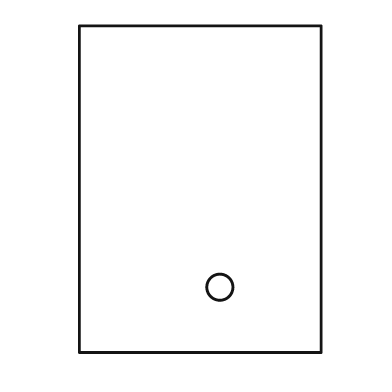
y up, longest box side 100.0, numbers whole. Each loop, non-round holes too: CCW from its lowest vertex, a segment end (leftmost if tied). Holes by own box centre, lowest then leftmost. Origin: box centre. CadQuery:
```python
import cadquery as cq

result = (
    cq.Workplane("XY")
    .moveTo(-37.0, -50.0)
    .lineTo(37.0, -50.0)
    .lineTo(37.0, 50.0)
    .lineTo(-37.0, 50.0)
    .close()
    .moveTo(6.0, -30.0)
    .circle(4.0)
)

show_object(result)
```